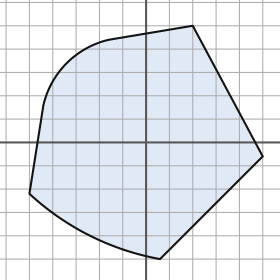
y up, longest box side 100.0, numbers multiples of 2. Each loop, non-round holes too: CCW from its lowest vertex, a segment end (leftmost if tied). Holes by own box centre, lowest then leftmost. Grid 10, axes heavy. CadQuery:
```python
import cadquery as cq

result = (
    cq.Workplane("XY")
    .moveTo(6.0, -50.0)
    .lineTo(50.0, -6.0)
    .lineTo(20.0, 50.0)
    .lineTo(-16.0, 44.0)
    .threePointArc((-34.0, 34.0), (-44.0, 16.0))
    .lineTo(-50.0, -22.0)
    .threePointArc((-24.0, -40.0), (6.0, -50.0))
    .close()
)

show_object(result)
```